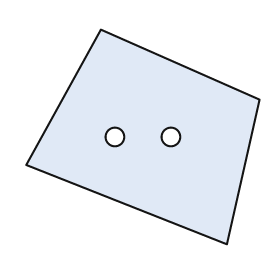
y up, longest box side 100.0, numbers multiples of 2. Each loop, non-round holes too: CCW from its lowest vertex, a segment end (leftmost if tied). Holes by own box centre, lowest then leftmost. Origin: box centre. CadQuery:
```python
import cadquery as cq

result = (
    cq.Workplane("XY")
    .moveTo(36.0, -46.0)
    .lineTo(50.0, 16.0)
    .lineTo(-18.0, 46.0)
    .lineTo(-50.0, -12.0)
    .close()
    .moveTo(-12.0, 0.0)
    .circle(4.0)
    .moveTo(12.0, 0.0)
    .circle(4.0)
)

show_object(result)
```